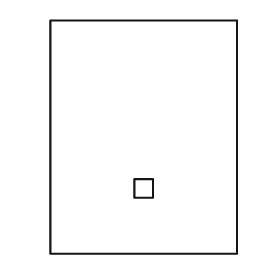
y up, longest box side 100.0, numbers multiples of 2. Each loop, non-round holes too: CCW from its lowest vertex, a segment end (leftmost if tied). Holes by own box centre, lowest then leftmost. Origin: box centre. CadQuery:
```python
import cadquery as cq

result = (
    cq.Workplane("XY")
    .moveTo(-40.0, -50.0)
    .lineTo(40.0, -50.0)
    .lineTo(40.0, 50.0)
    .lineTo(-40.0, 50.0)
    .close()
    .moveTo(-4.0, -26.0)
    .lineTo(4.0, -26.0)
    .lineTo(4.0, -18.0)
    .lineTo(-4.0, -18.0)
    .close()
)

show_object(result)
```